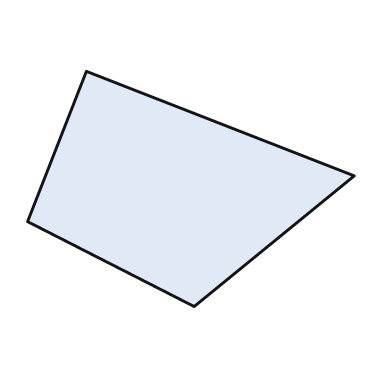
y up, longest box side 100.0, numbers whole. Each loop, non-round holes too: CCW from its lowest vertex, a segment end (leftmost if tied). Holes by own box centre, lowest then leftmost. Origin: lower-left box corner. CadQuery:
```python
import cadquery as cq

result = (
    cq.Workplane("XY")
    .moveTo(51.0, 0.0)
    .lineTo(100.0, 40.0)
    .lineTo(18.0, 72.0)
    .lineTo(0.0, 26.0)
    .close()
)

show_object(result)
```